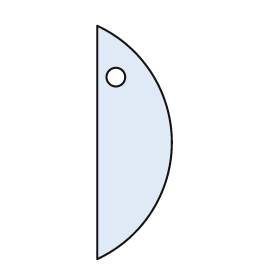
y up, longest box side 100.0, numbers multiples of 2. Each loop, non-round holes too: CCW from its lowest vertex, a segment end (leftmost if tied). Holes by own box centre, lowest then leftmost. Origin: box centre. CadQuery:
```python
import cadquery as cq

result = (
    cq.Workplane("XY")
    .moveTo(-16.0, -50.0)
    .threePointArc((16.0, 0.0), (-16.0, 50.0))
    .close()
    .moveTo(-8.0, 28.0)
    .circle(4.0)
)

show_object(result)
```